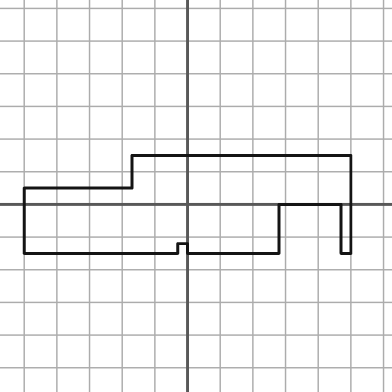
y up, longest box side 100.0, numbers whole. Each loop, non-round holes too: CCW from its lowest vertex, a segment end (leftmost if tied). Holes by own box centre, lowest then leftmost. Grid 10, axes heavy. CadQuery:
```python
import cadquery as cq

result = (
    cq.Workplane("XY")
    .moveTo(-50.0, -15.0)
    .lineTo(-3.0, -15.0)
    .lineTo(-3.0, -12.0)
    .lineTo(0.0, -12.0)
    .lineTo(0.0, -15.0)
    .lineTo(28.0, -15.0)
    .lineTo(28.0, 0.0)
    .lineTo(47.0, 0.0)
    .lineTo(47.0, -15.0)
    .lineTo(50.0, -15.0)
    .lineTo(50.0, 15.0)
    .lineTo(-17.0, 15.0)
    .lineTo(-17.0, 5.0)
    .lineTo(-50.0, 5.0)
    .close()
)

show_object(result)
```